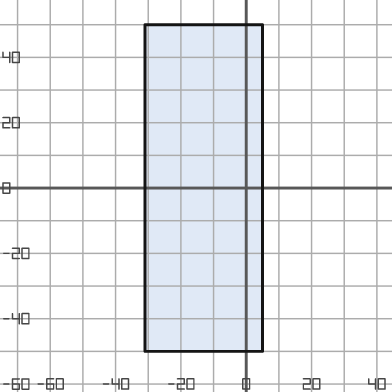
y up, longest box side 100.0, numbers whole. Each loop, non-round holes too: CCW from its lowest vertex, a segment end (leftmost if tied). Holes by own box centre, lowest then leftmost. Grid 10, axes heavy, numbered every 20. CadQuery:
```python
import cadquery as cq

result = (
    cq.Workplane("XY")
    .moveTo(-31.0, -50.0)
    .lineTo(5.0, -50.0)
    .lineTo(5.0, 50.0)
    .lineTo(-31.0, 50.0)
    .close()
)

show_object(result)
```